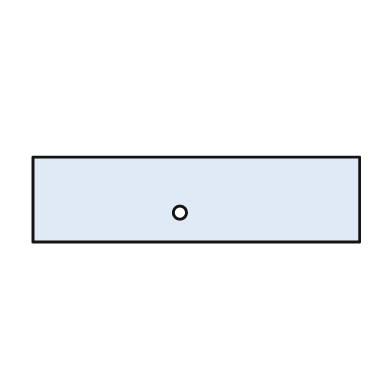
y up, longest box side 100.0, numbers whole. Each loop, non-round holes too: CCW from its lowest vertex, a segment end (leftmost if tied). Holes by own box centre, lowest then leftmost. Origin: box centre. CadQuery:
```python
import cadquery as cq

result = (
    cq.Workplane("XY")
    .moveTo(-50.0, -13.0)
    .lineTo(50.0, -13.0)
    .lineTo(50.0, 13.0)
    .lineTo(-50.0, 13.0)
    .close()
    .moveTo(-5.0, -4.0)
    .circle(2.0)
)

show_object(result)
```